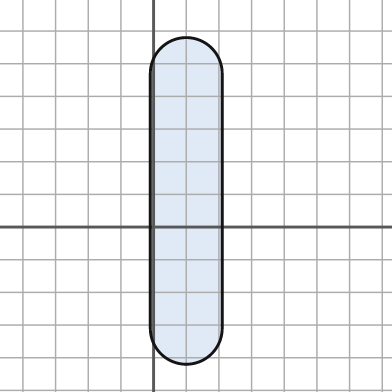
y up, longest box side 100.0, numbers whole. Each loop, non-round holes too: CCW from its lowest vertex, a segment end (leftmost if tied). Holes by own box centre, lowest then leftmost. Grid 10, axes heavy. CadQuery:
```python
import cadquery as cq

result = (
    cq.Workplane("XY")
    .moveTo(-1.0, -31.0)
    .threePointArc((10.0, -42.0), (21.0, -31.0))
    .lineTo(21.0, 47.0)
    .threePointArc((10.0, 58.0), (-1.0, 47.0))
    .close()
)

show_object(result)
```